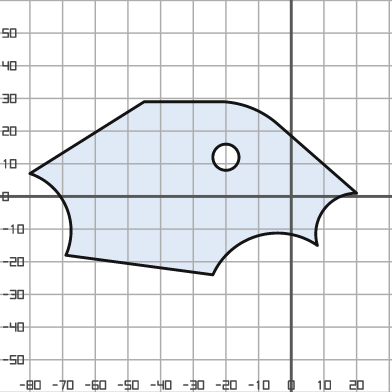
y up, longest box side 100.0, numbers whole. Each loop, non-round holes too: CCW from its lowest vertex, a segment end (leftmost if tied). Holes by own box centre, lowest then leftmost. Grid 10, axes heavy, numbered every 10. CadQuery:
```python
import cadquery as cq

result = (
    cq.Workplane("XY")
    .moveTo(-24.0, -24.0)
    .threePointArc((-10.0, -12.0), (8.0, -15.0))
    .threePointArc((10.0, -4.0), (20.0, 1.0))
    .lineTo(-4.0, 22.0)
    .threePointArc((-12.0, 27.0), (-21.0, 29.0))
    .lineTo(-45.0, 29.0)
    .lineTo(-80.0, 7.0)
    .threePointArc((-69.0, -3.0), (-69.0, -18.0))
    .close()
    .moveTo(-20.0, 12.0)
    .circle(4.0)
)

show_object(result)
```